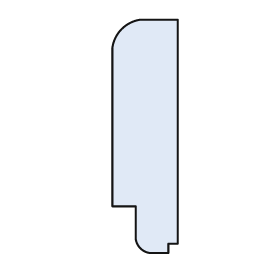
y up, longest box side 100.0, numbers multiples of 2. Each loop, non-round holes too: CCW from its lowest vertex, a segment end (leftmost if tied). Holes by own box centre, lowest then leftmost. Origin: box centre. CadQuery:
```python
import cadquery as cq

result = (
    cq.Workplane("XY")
    .moveTo(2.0, -50.0)
    .lineTo(10.0, -50.0)
    .lineTo(10.0, -46.0)
    .lineTo(14.0, -46.0)
    .lineTo(14.0, 50.0)
    .lineTo(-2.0, 50.0)
    .threePointArc((-10.0, 46.0), (-14.0, 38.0))
    .lineTo(-14.0, -30.0)
    .lineTo(-4.0, -30.0)
    .lineTo(-4.0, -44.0)
    .threePointArc((-2.0, -48.0), (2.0, -50.0))
    .close()
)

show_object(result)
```